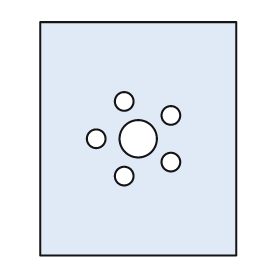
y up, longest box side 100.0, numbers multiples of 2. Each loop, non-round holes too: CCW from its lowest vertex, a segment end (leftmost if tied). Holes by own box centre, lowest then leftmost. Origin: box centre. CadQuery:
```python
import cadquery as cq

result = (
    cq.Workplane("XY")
    .moveTo(-42.0, -50.0)
    .lineTo(42.0, -50.0)
    .lineTo(42.0, 50.0)
    .lineTo(-42.0, 50.0)
    .close()
    .moveTo(-6.0, -16.0)
    .circle(4.0)
    .moveTo(14.0, -10.0)
    .circle(4.0)
    .moveTo(-18.0, 0.0)
    .circle(4.0)
    .moveTo(0.0, 0.0)
    .circle(8.0)
    .moveTo(14.0, 10.0)
    .circle(4.0)
    .moveTo(-6.0, 16.0)
    .circle(4.0)
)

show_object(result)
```